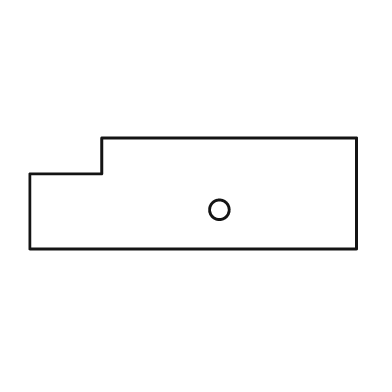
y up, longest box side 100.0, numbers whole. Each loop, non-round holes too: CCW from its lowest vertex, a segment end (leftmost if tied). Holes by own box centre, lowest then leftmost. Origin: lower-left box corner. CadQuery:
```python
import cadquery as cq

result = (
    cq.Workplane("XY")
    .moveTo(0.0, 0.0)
    .lineTo(100.0, 0.0)
    .lineTo(100.0, 34.0)
    .lineTo(22.0, 34.0)
    .lineTo(22.0, 23.0)
    .lineTo(0.0, 23.0)
    .close()
    .moveTo(58.0, 12.0)
    .circle(3.0)
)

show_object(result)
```